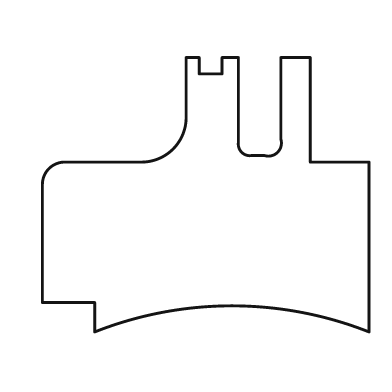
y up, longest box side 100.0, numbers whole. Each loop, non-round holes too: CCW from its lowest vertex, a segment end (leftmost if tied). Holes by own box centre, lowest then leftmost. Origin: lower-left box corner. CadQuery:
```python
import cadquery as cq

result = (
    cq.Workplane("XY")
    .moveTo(16.0, 0.0)
    .threePointArc((58.0, 8.0), (100.0, 0.0))
    .lineTo(100.0, 52.0)
    .lineTo(82.0, 52.0)
    .lineTo(82.0, 84.0)
    .lineTo(73.0, 84.0)
    .lineTo(73.0, 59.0)
    .threePointArc((72.0, 55.0), (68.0, 54.0))
    .lineTo(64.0, 54.0)
    .threePointArc((61.0, 55.0), (60.0, 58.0))
    .lineTo(60.0, 84.0)
    .lineTo(55.0, 84.0)
    .lineTo(55.0, 79.0)
    .lineTo(48.0, 79.0)
    .lineTo(48.0, 84.0)
    .lineTo(44.0, 84.0)
    .lineTo(44.0, 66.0)
    .threePointArc((40.0, 56.0), (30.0, 52.0))
    .lineTo(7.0, 52.0)
    .threePointArc((2.0, 50.0), (0.0, 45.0))
    .lineTo(0.0, 9.0)
    .lineTo(16.0, 9.0)
    .close()
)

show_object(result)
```